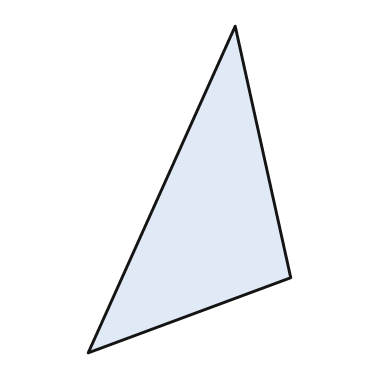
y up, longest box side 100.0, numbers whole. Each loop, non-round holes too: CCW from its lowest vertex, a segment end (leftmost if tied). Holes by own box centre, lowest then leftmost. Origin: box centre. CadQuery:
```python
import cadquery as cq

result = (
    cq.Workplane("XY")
    .moveTo(-31.0, -50.0)
    .lineTo(31.0, -27.0)
    .lineTo(14.0, 50.0)
    .close()
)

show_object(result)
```